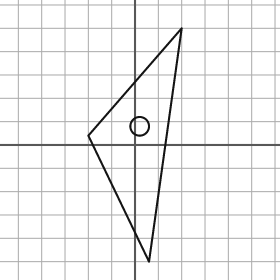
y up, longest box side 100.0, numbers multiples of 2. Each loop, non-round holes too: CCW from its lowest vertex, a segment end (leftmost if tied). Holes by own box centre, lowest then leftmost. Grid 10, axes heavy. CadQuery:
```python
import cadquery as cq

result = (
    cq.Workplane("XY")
    .moveTo(6.0, -50.0)
    .lineTo(20.0, 50.0)
    .lineTo(-20.0, 4.0)
    .close()
    .moveTo(2.0, 8.0)
    .circle(4.0)
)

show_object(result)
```